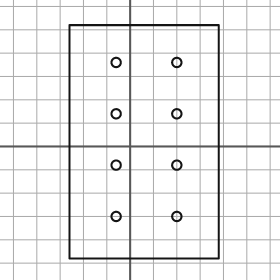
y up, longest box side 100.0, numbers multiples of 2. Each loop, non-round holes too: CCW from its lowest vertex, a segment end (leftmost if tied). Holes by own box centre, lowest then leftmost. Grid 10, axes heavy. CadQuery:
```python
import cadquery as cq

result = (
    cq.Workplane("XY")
    .moveTo(-26.0, -48.0)
    .lineTo(38.0, -48.0)
    .lineTo(38.0, 52.0)
    .lineTo(-26.0, 52.0)
    .close()
    .moveTo(-6.0, -30.0)
    .circle(2.0)
    .moveTo(20.0, -30.0)
    .circle(2.0)
    .moveTo(-6.0, -8.0)
    .circle(2.0)
    .moveTo(20.0, -8.0)
    .circle(2.0)
    .moveTo(-6.0, 14.0)
    .circle(2.0)
    .moveTo(20.0, 14.0)
    .circle(2.0)
    .moveTo(-6.0, 36.0)
    .circle(2.0)
    .moveTo(20.0, 36.0)
    .circle(2.0)
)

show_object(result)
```